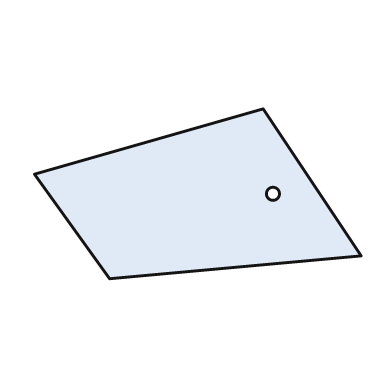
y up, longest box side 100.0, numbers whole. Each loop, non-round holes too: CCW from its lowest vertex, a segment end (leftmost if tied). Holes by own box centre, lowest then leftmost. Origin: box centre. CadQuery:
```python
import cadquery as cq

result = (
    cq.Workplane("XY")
    .moveTo(-27.0, -26.0)
    .lineTo(50.0, -19.0)
    .lineTo(20.0, 26.0)
    .lineTo(-50.0, 6.0)
    .close()
    .moveTo(23.0, 0.0)
    .circle(2.0)
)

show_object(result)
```